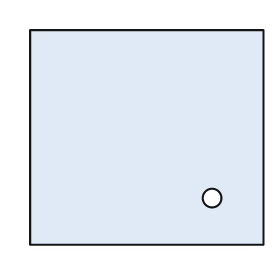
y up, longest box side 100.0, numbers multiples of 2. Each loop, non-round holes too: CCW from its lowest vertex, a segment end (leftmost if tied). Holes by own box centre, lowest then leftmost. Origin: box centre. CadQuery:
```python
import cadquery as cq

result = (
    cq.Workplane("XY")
    .moveTo(-50.0, -46.0)
    .lineTo(50.0, -46.0)
    .lineTo(50.0, 46.0)
    .lineTo(-50.0, 46.0)
    .close()
    .moveTo(28.0, -26.0)
    .circle(4.0)
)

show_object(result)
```